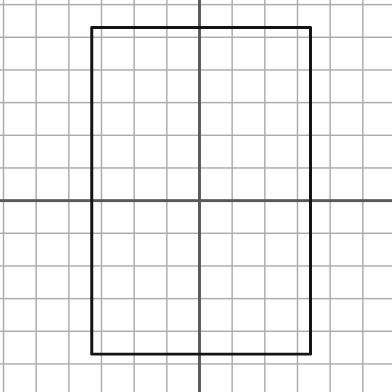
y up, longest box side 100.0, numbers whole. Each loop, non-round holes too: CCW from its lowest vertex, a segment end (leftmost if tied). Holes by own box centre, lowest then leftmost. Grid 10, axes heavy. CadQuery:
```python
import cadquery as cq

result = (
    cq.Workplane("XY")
    .moveTo(-33.0, -47.0)
    .lineTo(34.0, -47.0)
    .lineTo(34.0, 53.0)
    .lineTo(-33.0, 53.0)
    .close()
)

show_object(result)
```